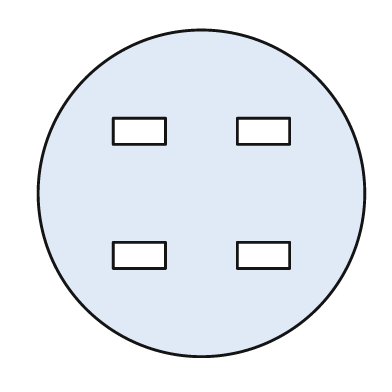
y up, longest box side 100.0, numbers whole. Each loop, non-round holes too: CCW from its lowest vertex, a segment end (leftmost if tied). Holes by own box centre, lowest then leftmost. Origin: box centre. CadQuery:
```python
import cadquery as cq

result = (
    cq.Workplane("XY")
    .moveTo(0.0, 0.0)
    .circle(50.0)
    .moveTo(-27.0, -23.0)
    .lineTo(-11.0, -23.0)
    .lineTo(-11.0, -15.0)
    .lineTo(-27.0, -15.0)
    .close()
    .moveTo(11.0, -23.0)
    .lineTo(27.0, -23.0)
    .lineTo(27.0, -15.0)
    .lineTo(11.0, -15.0)
    .close()
    .moveTo(-27.0, 15.0)
    .lineTo(-11.0, 15.0)
    .lineTo(-11.0, 23.0)
    .lineTo(-27.0, 23.0)
    .close()
    .moveTo(11.0, 15.0)
    .lineTo(27.0, 15.0)
    .lineTo(27.0, 23.0)
    .lineTo(11.0, 23.0)
    .close()
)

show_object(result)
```